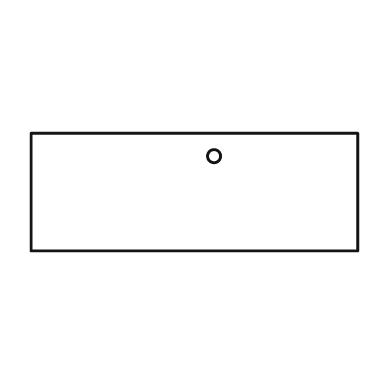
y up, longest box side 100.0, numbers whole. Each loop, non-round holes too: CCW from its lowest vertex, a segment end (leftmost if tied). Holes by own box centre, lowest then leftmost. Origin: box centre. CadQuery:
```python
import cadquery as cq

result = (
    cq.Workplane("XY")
    .moveTo(-50.0, -18.0)
    .lineTo(50.0, -18.0)
    .lineTo(50.0, 18.0)
    .lineTo(-50.0, 18.0)
    .close()
    .moveTo(6.0, 11.0)
    .circle(2.0)
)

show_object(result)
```